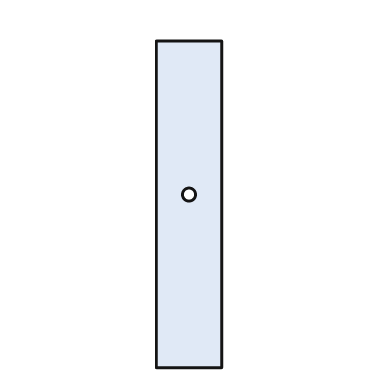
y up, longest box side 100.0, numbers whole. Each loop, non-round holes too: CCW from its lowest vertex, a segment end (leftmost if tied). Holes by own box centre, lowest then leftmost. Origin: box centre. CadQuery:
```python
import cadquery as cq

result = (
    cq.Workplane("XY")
    .moveTo(-10.0, -50.0)
    .lineTo(10.0, -50.0)
    .lineTo(10.0, 50.0)
    .lineTo(-10.0, 50.0)
    .close()
    .moveTo(0.0, 3.0)
    .circle(2.0)
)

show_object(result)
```